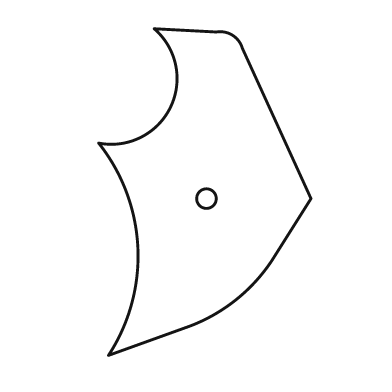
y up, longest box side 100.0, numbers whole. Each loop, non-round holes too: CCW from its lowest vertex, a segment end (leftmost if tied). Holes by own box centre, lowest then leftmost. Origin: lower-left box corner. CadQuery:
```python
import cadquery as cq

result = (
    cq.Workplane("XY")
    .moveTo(3.0, 0.0)
    .lineTo(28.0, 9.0)
    .threePointArc((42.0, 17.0), (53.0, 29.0))
    .lineTo(65.0, 48.0)
    .lineTo(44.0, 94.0)
    .threePointArc((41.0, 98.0), (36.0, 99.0))
    .lineTo(17.0, 100.0)
    .threePointArc((22.0, 76.0), (0.0, 65.0))
    .threePointArc((12.0, 33.0), (3.0, 0.0))
    .close()
    .moveTo(33.0, 48.0)
    .circle(3.0)
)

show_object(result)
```